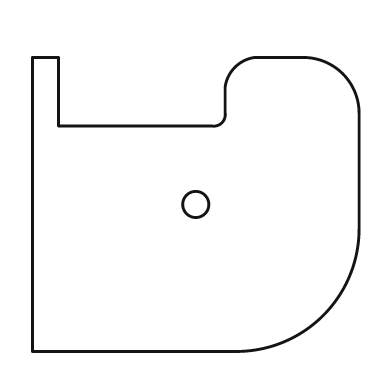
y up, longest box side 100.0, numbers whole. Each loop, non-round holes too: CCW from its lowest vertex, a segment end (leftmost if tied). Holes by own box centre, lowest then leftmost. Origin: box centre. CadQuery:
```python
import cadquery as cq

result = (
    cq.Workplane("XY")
    .moveTo(-50.0, -45.0)
    .lineTo(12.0, -45.0)
    .threePointArc((39.0, -34.0), (50.0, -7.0))
    .lineTo(50.0, 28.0)
    .threePointArc((45.0, 40.0), (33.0, 45.0))
    .lineTo(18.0, 45.0)
    .threePointArc((12.0, 42.0), (9.0, 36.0))
    .lineTo(9.0, 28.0)
    .threePointArc((8.0, 25.0), (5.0, 24.0))
    .lineTo(-42.0, 24.0)
    .lineTo(-42.0, 45.0)
    .lineTo(-50.0, 45.0)
    .close()
    .moveTo(0.0, 0.0)
    .circle(4.0)
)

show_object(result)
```